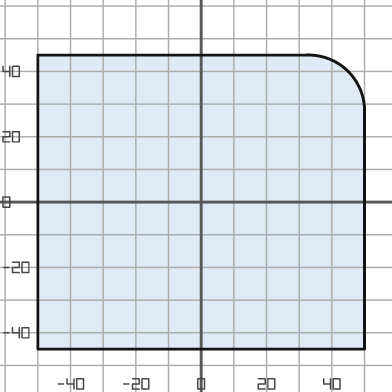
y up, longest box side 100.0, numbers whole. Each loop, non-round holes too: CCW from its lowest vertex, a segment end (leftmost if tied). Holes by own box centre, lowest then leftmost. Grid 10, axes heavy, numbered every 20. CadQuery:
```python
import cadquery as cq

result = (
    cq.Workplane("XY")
    .moveTo(-50.0, -45.0)
    .lineTo(50.0, -45.0)
    .lineTo(50.0, 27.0)
    .threePointArc((45.0, 40.0), (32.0, 45.0))
    .lineTo(-50.0, 45.0)
    .close()
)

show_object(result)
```